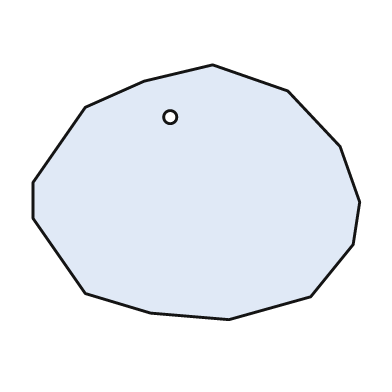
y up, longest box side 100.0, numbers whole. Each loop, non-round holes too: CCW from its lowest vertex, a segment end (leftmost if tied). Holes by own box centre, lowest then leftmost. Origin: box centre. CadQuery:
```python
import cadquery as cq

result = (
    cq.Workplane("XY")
    .moveTo(10.0, -39.0)
    .lineTo(35.0, -32.0)
    .lineTo(48.0, -16.0)
    .lineTo(50.0, -3.0)
    .lineTo(44.0, 14.0)
    .lineTo(28.0, 31.0)
    .lineTo(5.0, 39.0)
    .lineTo(-16.0, 34.0)
    .lineTo(-34.0, 26.0)
    .lineTo(-50.0, 3.0)
    .lineTo(-50.0, -8.0)
    .lineTo(-34.0, -31.0)
    .lineTo(-14.0, -37.0)
    .close()
    .moveTo(-8.0, 23.0)
    .circle(2.0)
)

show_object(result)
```